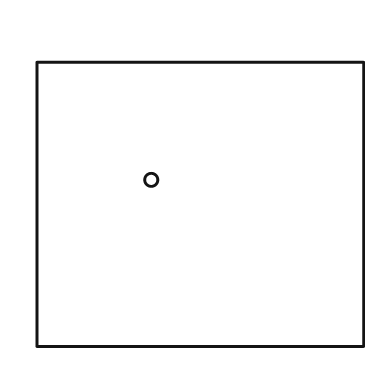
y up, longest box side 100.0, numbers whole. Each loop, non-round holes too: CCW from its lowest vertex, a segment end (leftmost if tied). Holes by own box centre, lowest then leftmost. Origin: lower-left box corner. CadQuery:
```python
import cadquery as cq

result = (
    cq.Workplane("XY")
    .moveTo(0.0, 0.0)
    .lineTo(100.0, 0.0)
    .lineTo(100.0, 87.0)
    .lineTo(0.0, 87.0)
    .close()
    .moveTo(35.0, 51.0)
    .circle(2.0)
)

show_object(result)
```